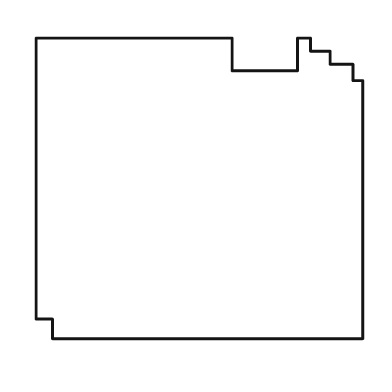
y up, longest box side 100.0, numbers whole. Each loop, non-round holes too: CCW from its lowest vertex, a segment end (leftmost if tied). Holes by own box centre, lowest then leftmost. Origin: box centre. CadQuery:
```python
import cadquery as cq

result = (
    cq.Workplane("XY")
    .moveTo(-45.0, -46.0)
    .lineTo(50.0, -46.0)
    .lineTo(50.0, 33.0)
    .lineTo(47.0, 33.0)
    .lineTo(47.0, 38.0)
    .lineTo(40.0, 38.0)
    .lineTo(40.0, 42.0)
    .lineTo(34.0, 42.0)
    .lineTo(34.0, 46.0)
    .lineTo(30.0, 46.0)
    .lineTo(30.0, 36.0)
    .lineTo(10.0, 36.0)
    .lineTo(10.0, 46.0)
    .lineTo(-50.0, 46.0)
    .lineTo(-50.0, -40.0)
    .lineTo(-45.0, -40.0)
    .close()
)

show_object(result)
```